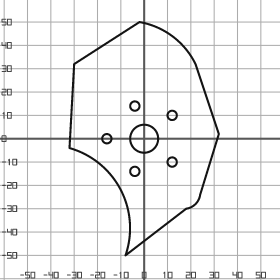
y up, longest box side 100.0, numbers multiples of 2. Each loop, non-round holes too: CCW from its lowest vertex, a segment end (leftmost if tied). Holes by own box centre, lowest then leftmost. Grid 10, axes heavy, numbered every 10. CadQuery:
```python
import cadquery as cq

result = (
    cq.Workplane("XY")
    .moveTo(-8.0, -50.0)
    .lineTo(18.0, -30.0)
    .threePointArc((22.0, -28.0), (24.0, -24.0))
    .lineTo(32.0, 2.0)
    .lineTo(22.0, 32.0)
    .threePointArc((12.0, 44.0), (-2.0, 50.0))
    .lineTo(-30.0, 32.0)
    .lineTo(-32.0, -4.0)
    .threePointArc((-10.0, -22.0), (-8.0, -50.0))
    .close()
    .moveTo(-4.0, -14.0)
    .circle(2.0)
    .moveTo(12.0, -10.0)
    .circle(2.0)
    .moveTo(-16.0, 0.0)
    .circle(2.0)
    .moveTo(0.0, 0.0)
    .circle(6.0)
    .moveTo(12.0, 10.0)
    .circle(2.0)
    .moveTo(-4.0, 14.0)
    .circle(2.0)
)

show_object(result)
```